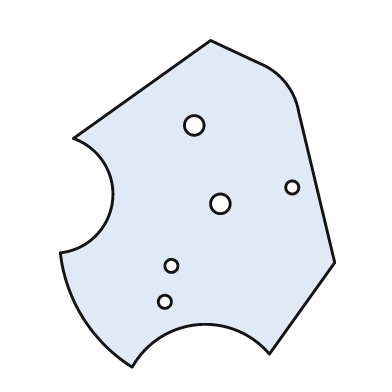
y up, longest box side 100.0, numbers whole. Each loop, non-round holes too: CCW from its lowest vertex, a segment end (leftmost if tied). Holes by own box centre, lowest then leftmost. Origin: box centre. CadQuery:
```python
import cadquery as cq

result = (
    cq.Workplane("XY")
    .moveTo(-20.0, -50.0)
    .threePointArc((0.0, -37.0), (22.0, -46.0))
    .lineTo(42.0, -18.0)
    .lineTo(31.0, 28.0)
    .threePointArc((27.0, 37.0), (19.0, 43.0))
    .lineTo(4.0, 50.0)
    .lineTo(-38.0, 20.0)
    .threePointArc((-26.0, 1.0), (-42.0, -15.0))
    .threePointArc((-35.0, -35.0), (-20.0, -50.0))
    .close()
    .moveTo(-10.0, -30.0)
    .circle(2.0)
    .moveTo(-8.0, -19.0)
    .circle(2.0)
    .moveTo(7.0, 0.0)
    .circle(3.0)
    .moveTo(29.0, 5.0)
    .circle(2.0)
    .moveTo(-1.0, 24.0)
    .circle(3.0)
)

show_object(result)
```